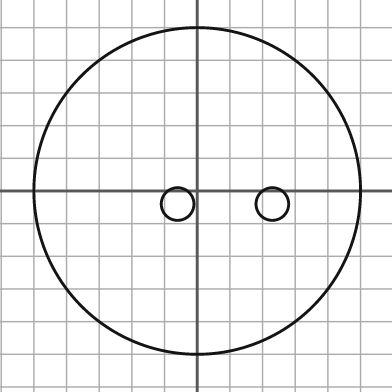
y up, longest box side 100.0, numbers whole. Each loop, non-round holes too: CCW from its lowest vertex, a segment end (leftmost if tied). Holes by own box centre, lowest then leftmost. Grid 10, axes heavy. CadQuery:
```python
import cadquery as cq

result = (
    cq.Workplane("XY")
    .moveTo(0.0, 0.0)
    .circle(50.0)
    .moveTo(-6.0, -4.0)
    .circle(5.0)
    .moveTo(23.0, -4.0)
    .circle(5.0)
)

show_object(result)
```